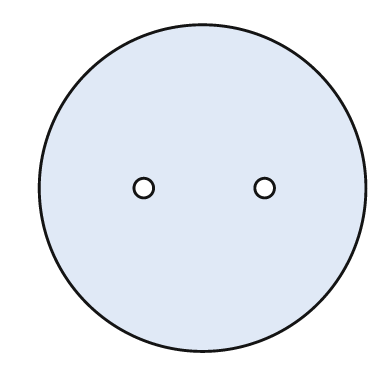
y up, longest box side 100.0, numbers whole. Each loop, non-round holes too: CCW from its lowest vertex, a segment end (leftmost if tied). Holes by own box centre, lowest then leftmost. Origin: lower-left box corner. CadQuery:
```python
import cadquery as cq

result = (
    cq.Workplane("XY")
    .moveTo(50.0, 50.0)
    .circle(50.0)
    .moveTo(32.0, 50.0)
    .circle(3.0)
    .moveTo(69.0, 50.0)
    .circle(3.0)
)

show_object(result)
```